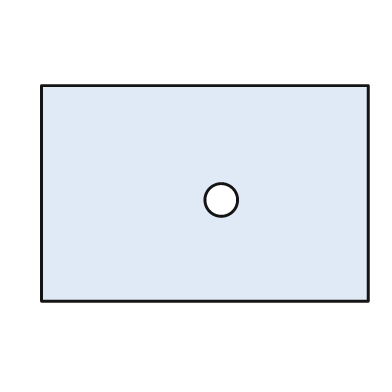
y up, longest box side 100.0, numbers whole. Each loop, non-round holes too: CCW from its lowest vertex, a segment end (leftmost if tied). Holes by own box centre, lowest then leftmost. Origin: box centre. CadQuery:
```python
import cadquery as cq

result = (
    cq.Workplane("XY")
    .moveTo(-50.0, -33.0)
    .lineTo(50.0, -33.0)
    .lineTo(50.0, 33.0)
    .lineTo(-50.0, 33.0)
    .close()
    .moveTo(5.0, -2.0)
    .circle(5.0)
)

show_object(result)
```